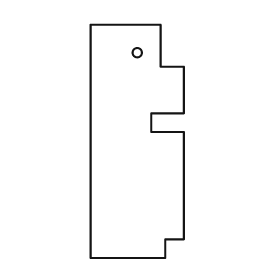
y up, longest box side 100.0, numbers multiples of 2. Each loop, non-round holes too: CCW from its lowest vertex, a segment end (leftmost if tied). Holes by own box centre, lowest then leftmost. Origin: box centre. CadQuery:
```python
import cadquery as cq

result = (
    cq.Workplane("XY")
    .moveTo(-20.0, -50.0)
    .lineTo(12.0, -50.0)
    .lineTo(12.0, -42.0)
    .lineTo(20.0, -42.0)
    .lineTo(20.0, 4.0)
    .lineTo(6.0, 4.0)
    .lineTo(6.0, 12.0)
    .lineTo(20.0, 12.0)
    .lineTo(20.0, 32.0)
    .lineTo(10.0, 32.0)
    .lineTo(10.0, 50.0)
    .lineTo(-20.0, 50.0)
    .close()
    .moveTo(0.0, 38.0)
    .circle(2.0)
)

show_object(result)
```